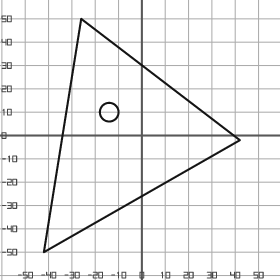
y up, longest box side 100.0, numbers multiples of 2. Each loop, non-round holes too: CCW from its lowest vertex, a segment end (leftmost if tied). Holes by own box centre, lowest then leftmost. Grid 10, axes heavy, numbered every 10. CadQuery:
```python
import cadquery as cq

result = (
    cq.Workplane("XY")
    .moveTo(-42.0, -50.0)
    .lineTo(42.0, -2.0)
    .lineTo(-26.0, 50.0)
    .close()
    .moveTo(-14.0, 10.0)
    .circle(4.0)
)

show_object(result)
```